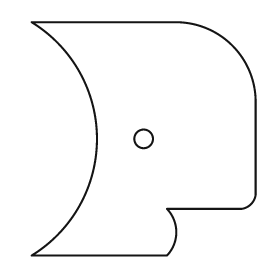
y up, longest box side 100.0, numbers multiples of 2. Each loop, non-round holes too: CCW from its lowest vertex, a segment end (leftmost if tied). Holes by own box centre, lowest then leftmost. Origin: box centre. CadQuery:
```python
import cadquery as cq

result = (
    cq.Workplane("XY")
    .moveTo(-48.0, -50.0)
    .lineTo(10.0, -50.0)
    .threePointArc((14.0, -40.0), (10.0, -30.0))
    .lineTo(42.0, -30.0)
    .threePointArc((46.0, -28.0), (48.0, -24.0))
    .lineTo(48.0, 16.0)
    .threePointArc((38.0, 40.0), (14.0, 50.0))
    .lineTo(-48.0, 50.0)
    .threePointArc((-20.0, 0.0), (-48.0, -50.0))
    .close()
    .moveTo(0.0, 0.0)
    .circle(4.0)
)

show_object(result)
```